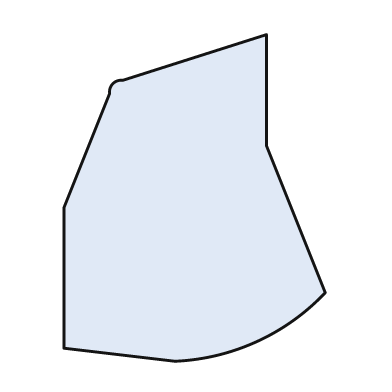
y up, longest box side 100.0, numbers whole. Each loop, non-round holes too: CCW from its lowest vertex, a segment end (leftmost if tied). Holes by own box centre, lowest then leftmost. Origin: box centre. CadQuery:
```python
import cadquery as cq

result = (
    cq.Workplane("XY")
    .moveTo(-6.0, -50.0)
    .threePointArc((19.0, -44.0), (40.0, -29.0))
    .lineTo(22.0, 16.0)
    .lineTo(22.0, 50.0)
    .lineTo(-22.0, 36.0)
    .threePointArc((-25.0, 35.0), (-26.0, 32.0))
    .lineTo(-40.0, -3.0)
    .lineTo(-40.0, -46.0)
    .close()
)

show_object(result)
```